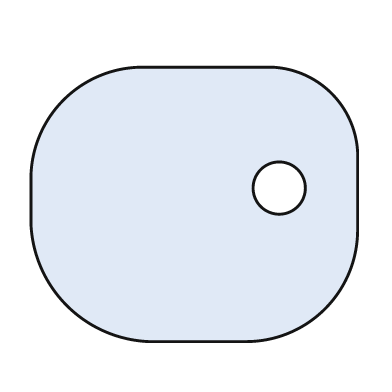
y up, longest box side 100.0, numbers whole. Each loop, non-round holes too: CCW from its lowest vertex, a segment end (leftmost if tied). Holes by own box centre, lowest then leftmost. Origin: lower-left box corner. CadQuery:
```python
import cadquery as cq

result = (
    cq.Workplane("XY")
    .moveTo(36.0, 0.0)
    .lineTo(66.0, 0.0)
    .threePointArc((90.0, 10.0), (100.0, 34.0))
    .lineTo(100.0, 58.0)
    .threePointArc((92.0, 76.0), (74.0, 84.0))
    .lineTo(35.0, 84.0)
    .threePointArc((10.0, 74.0), (0.0, 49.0))
    .lineTo(0.0, 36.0)
    .threePointArc((11.0, 11.0), (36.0, 0.0))
    .close()
    .moveTo(76.0, 47.0)
    .circle(8.0)
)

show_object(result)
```